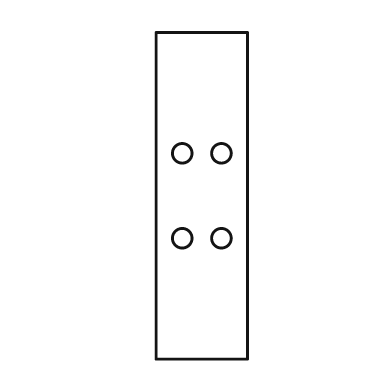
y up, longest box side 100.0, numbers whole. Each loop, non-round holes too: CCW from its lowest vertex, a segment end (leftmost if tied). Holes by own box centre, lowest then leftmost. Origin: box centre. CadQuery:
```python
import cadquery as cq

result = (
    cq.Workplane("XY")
    .moveTo(-14.0, -50.0)
    .lineTo(14.0, -50.0)
    .lineTo(14.0, 50.0)
    .lineTo(-14.0, 50.0)
    .close()
    .moveTo(-6.0, -13.0)
    .circle(3.0)
    .moveTo(6.0, -13.0)
    .circle(3.0)
    .moveTo(-6.0, 13.0)
    .circle(3.0)
    .moveTo(6.0, 13.0)
    .circle(3.0)
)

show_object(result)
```